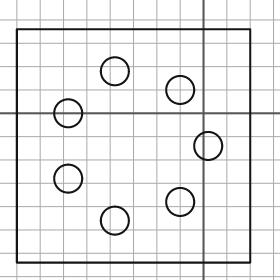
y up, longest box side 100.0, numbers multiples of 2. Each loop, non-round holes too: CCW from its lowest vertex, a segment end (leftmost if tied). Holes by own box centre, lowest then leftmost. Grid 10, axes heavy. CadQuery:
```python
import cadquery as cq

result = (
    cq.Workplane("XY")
    .moveTo(-80.0, -64.0)
    .lineTo(20.0, -64.0)
    .lineTo(20.0, 36.0)
    .lineTo(-80.0, 36.0)
    .close()
    .moveTo(-38.0, -46.0)
    .circle(6.0)
    .moveTo(-10.0, -38.0)
    .circle(6.0)
    .moveTo(-58.0, -28.0)
    .circle(6.0)
    .moveTo(2.0, -14.0)
    .circle(6.0)
    .moveTo(-58.0, 0.0)
    .circle(6.0)
    .moveTo(-10.0, 10.0)
    .circle(6.0)
    .moveTo(-38.0, 18.0)
    .circle(6.0)
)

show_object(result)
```